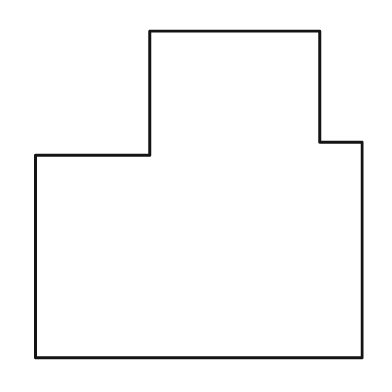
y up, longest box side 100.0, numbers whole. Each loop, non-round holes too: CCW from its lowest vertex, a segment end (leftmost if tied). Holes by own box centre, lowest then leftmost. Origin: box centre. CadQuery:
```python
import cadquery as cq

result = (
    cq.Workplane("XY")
    .moveTo(-50.0, -50.0)
    .lineTo(50.0, -50.0)
    .lineTo(50.0, 16.0)
    .lineTo(37.0, 16.0)
    .lineTo(37.0, 50.0)
    .lineTo(-15.0, 50.0)
    .lineTo(-15.0, 12.0)
    .lineTo(-50.0, 12.0)
    .close()
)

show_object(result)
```